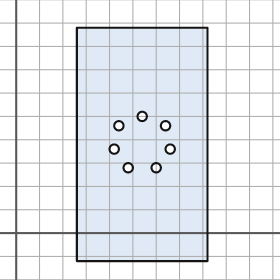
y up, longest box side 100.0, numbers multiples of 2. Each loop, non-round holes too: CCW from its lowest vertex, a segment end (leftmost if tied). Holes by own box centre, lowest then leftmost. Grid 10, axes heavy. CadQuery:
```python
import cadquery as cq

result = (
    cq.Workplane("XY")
    .moveTo(26.0, -12.0)
    .lineTo(82.0, -12.0)
    .lineTo(82.0, 88.0)
    .lineTo(26.0, 88.0)
    .close()
    .moveTo(48.0, 28.0)
    .circle(2.0)
    .moveTo(60.0, 28.0)
    .circle(2.0)
    .moveTo(42.0, 36.0)
    .circle(2.0)
    .moveTo(66.0, 36.0)
    .circle(2.0)
    .moveTo(44.0, 46.0)
    .circle(2.0)
    .moveTo(64.0, 46.0)
    .circle(2.0)
    .moveTo(54.0, 50.0)
    .circle(2.0)
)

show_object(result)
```